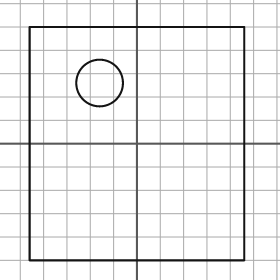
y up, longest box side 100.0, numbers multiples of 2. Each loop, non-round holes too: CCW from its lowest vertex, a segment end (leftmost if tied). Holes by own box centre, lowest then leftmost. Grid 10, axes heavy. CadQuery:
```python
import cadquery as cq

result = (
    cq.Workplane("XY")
    .moveTo(-46.0, -50.0)
    .lineTo(46.0, -50.0)
    .lineTo(46.0, 50.0)
    .lineTo(-46.0, 50.0)
    .close()
    .moveTo(-16.0, 26.0)
    .circle(10.0)
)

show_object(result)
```